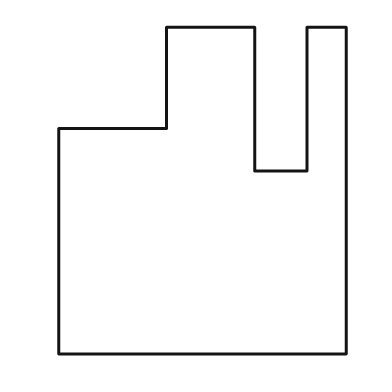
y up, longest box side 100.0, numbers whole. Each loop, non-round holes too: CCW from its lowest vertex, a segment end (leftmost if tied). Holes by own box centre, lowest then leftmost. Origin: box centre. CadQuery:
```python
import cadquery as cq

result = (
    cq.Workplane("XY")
    .moveTo(-44.0, -50.0)
    .lineTo(44.0, -50.0)
    .lineTo(44.0, 50.0)
    .lineTo(32.0, 50.0)
    .lineTo(32.0, 6.0)
    .lineTo(16.0, 6.0)
    .lineTo(16.0, 50.0)
    .lineTo(-11.0, 50.0)
    .lineTo(-11.0, 19.0)
    .lineTo(-44.0, 19.0)
    .close()
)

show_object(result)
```